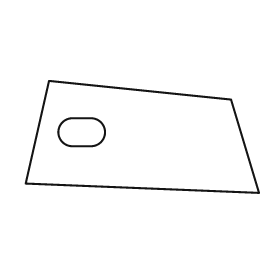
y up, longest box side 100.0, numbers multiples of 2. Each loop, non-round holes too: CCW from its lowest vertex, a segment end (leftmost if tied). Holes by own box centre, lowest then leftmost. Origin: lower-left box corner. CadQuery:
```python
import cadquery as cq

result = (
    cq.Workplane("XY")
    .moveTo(100.0, 0.0)
    .lineTo(88.0, 40.0)
    .lineTo(10.0, 48.0)
    .lineTo(0.0, 4.0)
    .close()
    .moveTo(20.0, 20.0)
    .lineTo(28.0, 20.0)
    .threePointArc((34.0, 26.0), (28.0, 32.0))
    .lineTo(20.0, 32.0)
    .threePointArc((14.0, 26.0), (20.0, 20.0))
    .close()
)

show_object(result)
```